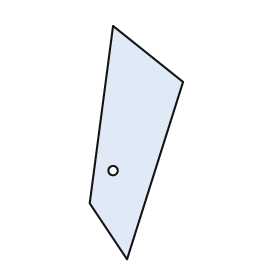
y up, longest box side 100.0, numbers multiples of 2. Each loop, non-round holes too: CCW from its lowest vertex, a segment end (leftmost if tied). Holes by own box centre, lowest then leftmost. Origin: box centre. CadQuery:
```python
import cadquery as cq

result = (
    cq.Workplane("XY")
    .moveTo(-4.0, -50.0)
    .lineTo(20.0, 26.0)
    .lineTo(-10.0, 50.0)
    .lineTo(-20.0, -26.0)
    .close()
    .moveTo(-10.0, -12.0)
    .circle(2.0)
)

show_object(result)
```